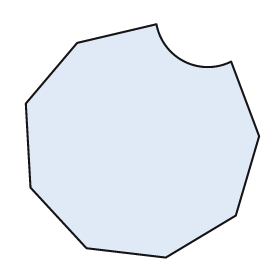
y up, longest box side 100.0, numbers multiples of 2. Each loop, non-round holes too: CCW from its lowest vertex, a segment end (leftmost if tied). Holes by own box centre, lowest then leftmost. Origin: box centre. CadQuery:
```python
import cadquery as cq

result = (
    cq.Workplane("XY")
    .moveTo(10.0, -50.0)
    .lineTo(40.0, -32.0)
    .lineTo(50.0, 2.0)
    .lineTo(38.0, 34.0)
    .threePointArc((18.0, 34.0), (6.0, 50.0))
    .lineTo(-28.0, 42.0)
    .lineTo(-50.0, 16.0)
    .lineTo(-48.0, -20.0)
    .lineTo(-24.0, -46.0)
    .close()
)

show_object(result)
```